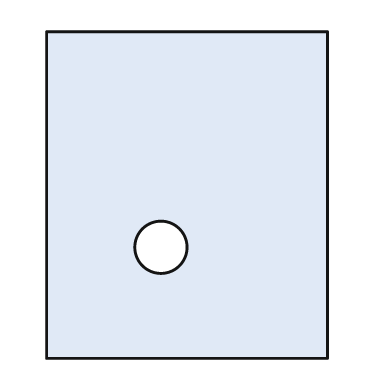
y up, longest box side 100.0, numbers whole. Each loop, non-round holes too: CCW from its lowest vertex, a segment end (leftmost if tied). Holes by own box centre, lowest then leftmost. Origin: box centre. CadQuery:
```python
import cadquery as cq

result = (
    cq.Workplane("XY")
    .moveTo(-43.0, -50.0)
    .lineTo(43.0, -50.0)
    .lineTo(43.0, 50.0)
    .lineTo(-43.0, 50.0)
    .close()
    .moveTo(-8.0, -16.0)
    .circle(8.0)
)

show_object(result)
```